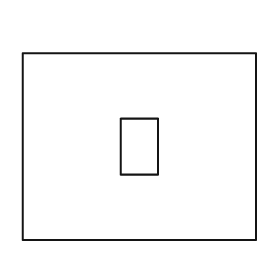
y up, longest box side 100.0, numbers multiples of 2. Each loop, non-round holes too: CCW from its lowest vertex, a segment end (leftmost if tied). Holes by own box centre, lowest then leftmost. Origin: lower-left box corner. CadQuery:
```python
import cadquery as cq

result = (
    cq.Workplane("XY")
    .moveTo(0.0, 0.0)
    .lineTo(100.0, 0.0)
    .lineTo(100.0, 80.0)
    .lineTo(0.0, 80.0)
    .close()
    .moveTo(42.0, 28.0)
    .lineTo(58.0, 28.0)
    .lineTo(58.0, 52.0)
    .lineTo(42.0, 52.0)
    .close()
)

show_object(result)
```